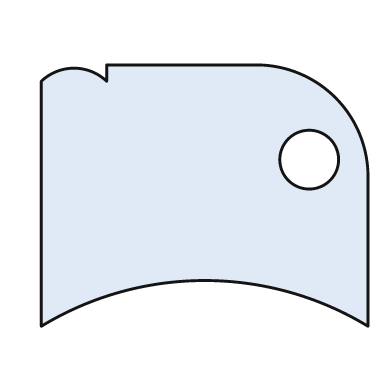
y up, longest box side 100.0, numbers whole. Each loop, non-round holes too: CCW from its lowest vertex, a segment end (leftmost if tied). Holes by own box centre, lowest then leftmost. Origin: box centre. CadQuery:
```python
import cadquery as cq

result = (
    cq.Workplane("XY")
    .moveTo(-50.0, -40.0)
    .threePointArc((0.0, -26.0), (50.0, -40.0))
    .lineTo(50.0, 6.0)
    .threePointArc((40.0, 30.0), (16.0, 40.0))
    .lineTo(-30.0, 40.0)
    .lineTo(-30.0, 35.0)
    .threePointArc((-40.0, 39.0), (-50.0, 35.0))
    .close()
    .moveTo(32.0, 11.0)
    .circle(9.0)
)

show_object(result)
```